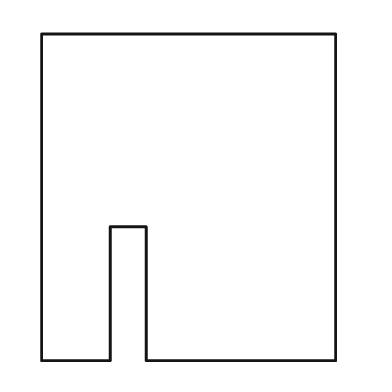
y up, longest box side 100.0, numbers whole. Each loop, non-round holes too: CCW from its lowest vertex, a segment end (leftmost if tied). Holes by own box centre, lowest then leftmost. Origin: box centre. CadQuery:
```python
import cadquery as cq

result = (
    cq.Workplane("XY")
    .moveTo(-45.0, -50.0)
    .lineTo(-24.0, -50.0)
    .lineTo(-24.0, -9.0)
    .lineTo(-13.0, -9.0)
    .lineTo(-13.0, -50.0)
    .lineTo(45.0, -50.0)
    .lineTo(45.0, 50.0)
    .lineTo(-45.0, 50.0)
    .close()
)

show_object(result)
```